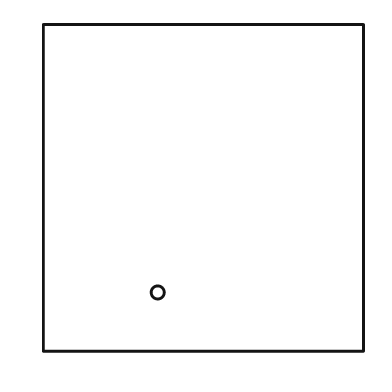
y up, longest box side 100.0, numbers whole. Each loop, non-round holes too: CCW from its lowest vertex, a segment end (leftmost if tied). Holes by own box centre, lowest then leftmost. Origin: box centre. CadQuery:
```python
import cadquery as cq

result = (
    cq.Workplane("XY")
    .moveTo(-49.0, -50.0)
    .lineTo(49.0, -50.0)
    .lineTo(49.0, 50.0)
    .lineTo(-49.0, 50.0)
    .close()
    .moveTo(-14.0, -32.0)
    .circle(2.0)
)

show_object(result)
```